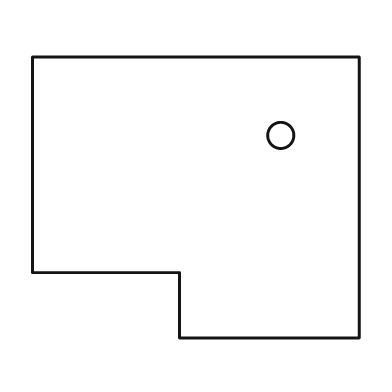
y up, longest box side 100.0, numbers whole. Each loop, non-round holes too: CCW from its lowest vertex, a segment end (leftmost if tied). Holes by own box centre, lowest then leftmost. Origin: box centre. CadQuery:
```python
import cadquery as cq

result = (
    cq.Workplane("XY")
    .moveTo(-5.0, -43.0)
    .lineTo(50.0, -43.0)
    .lineTo(50.0, 43.0)
    .lineTo(-50.0, 43.0)
    .lineTo(-50.0, -23.0)
    .lineTo(-5.0, -23.0)
    .close()
    .moveTo(26.0, 19.0)
    .circle(4.0)
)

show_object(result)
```